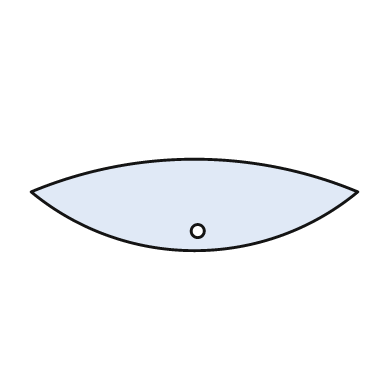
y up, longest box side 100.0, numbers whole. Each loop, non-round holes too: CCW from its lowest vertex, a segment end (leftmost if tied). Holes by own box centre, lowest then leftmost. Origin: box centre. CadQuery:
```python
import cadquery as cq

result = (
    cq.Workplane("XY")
    .moveTo(-50.0, 4.0)
    .threePointArc((0.0, -14.0), (50.0, 4.0))
    .threePointArc((0.0, 14.0), (-50.0, 4.0))
    .close()
    .moveTo(1.0, -8.0)
    .circle(2.0)
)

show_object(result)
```